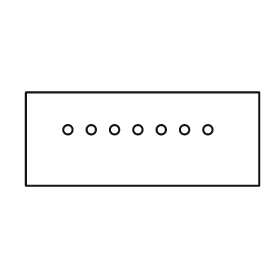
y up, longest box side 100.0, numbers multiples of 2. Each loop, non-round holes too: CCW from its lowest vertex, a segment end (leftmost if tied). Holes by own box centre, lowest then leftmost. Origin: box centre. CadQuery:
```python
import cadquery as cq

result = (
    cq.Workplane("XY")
    .moveTo(-50.0, -20.0)
    .lineTo(50.0, -20.0)
    .lineTo(50.0, 20.0)
    .lineTo(-50.0, 20.0)
    .close()
    .moveTo(-32.0, 4.0)
    .circle(2.0)
    .moveTo(-22.0, 4.0)
    .circle(2.0)
    .moveTo(-12.0, 4.0)
    .circle(2.0)
    .moveTo(-2.0, 4.0)
    .circle(2.0)
    .moveTo(8.0, 4.0)
    .circle(2.0)
    .moveTo(18.0, 4.0)
    .circle(2.0)
    .moveTo(28.0, 4.0)
    .circle(2.0)
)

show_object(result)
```